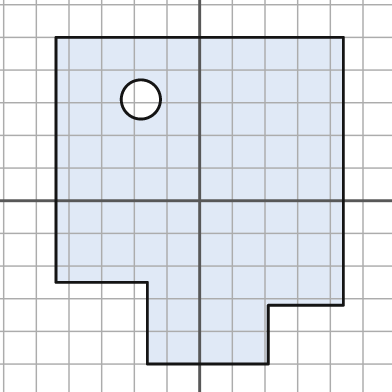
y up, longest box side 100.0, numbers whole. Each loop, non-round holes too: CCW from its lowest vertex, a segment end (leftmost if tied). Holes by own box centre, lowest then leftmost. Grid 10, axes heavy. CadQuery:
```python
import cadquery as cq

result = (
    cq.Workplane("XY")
    .moveTo(-16.0, -50.0)
    .lineTo(21.0, -50.0)
    .lineTo(21.0, -32.0)
    .lineTo(44.0, -32.0)
    .lineTo(44.0, 50.0)
    .lineTo(-44.0, 50.0)
    .lineTo(-44.0, -25.0)
    .lineTo(-16.0, -25.0)
    .close()
    .moveTo(-18.0, 31.0)
    .circle(6.0)
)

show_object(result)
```